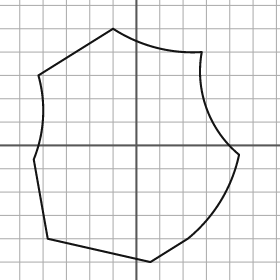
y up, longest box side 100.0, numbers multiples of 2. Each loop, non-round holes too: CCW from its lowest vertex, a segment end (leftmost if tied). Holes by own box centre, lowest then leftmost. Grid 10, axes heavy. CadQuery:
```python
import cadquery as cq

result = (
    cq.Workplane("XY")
    .moveTo(6.0, -50.0)
    .lineTo(22.0, -40.0)
    .threePointArc((36.0, -24.0), (44.0, -4.0))
    .threePointArc((30.0, 16.0), (28.0, 40.0))
    .threePointArc((8.0, 42.0), (-10.0, 50.0))
    .lineTo(-42.0, 30.0)
    .threePointArc((-40.0, 12.0), (-44.0, -6.0))
    .lineTo(-38.0, -40.0)
    .close()
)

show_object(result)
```